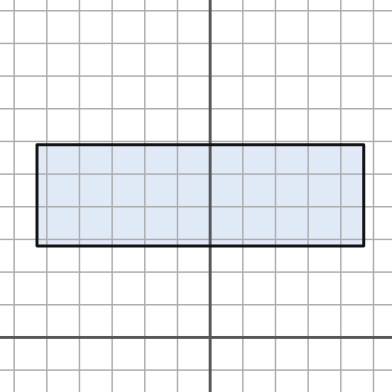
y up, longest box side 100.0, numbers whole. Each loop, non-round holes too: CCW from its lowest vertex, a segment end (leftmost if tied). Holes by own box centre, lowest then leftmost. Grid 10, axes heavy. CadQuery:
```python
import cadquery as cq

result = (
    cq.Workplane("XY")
    .moveTo(-53.0, 28.0)
    .lineTo(47.0, 28.0)
    .lineTo(47.0, 59.0)
    .lineTo(-53.0, 59.0)
    .close()
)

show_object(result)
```